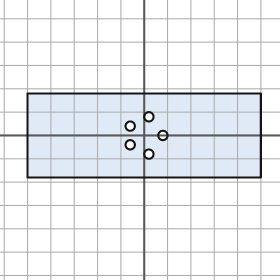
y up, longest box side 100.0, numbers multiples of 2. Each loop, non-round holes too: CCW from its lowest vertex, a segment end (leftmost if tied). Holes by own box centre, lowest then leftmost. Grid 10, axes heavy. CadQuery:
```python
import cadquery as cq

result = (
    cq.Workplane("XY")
    .moveTo(-50.0, -18.0)
    .lineTo(50.0, -18.0)
    .lineTo(50.0, 18.0)
    .lineTo(-50.0, 18.0)
    .close()
    .moveTo(2.0, -8.0)
    .circle(2.0)
    .moveTo(-6.0, -4.0)
    .circle(2.0)
    .moveTo(8.0, 0.0)
    .circle(2.0)
    .moveTo(-6.0, 4.0)
    .circle(2.0)
    .moveTo(2.0, 8.0)
    .circle(2.0)
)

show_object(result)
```